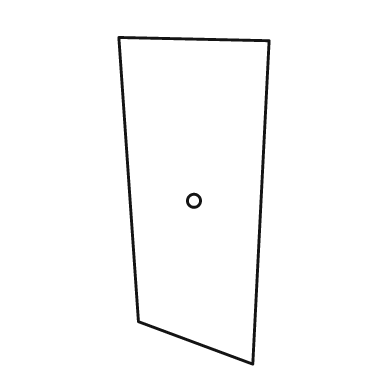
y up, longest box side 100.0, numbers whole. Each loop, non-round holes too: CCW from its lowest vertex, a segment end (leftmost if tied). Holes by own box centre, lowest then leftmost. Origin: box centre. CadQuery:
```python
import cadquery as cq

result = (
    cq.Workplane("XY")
    .moveTo(18.0, -50.0)
    .lineTo(23.0, 49.0)
    .lineTo(-23.0, 50.0)
    .lineTo(-17.0, -37.0)
    .close()
    .moveTo(0.0, 0.0)
    .circle(2.0)
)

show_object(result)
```